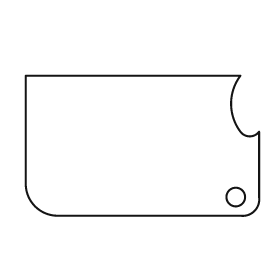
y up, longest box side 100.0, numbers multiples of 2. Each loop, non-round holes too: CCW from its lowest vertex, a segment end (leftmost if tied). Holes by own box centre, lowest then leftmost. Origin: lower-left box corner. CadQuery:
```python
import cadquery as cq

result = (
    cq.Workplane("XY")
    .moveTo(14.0, 0.0)
    .lineTo(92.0, 0.0)
    .threePointArc((98.0, 2.0), (100.0, 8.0))
    .lineTo(100.0, 36.0)
    .threePointArc((96.0, 34.0), (92.0, 36.0))
    .threePointArc((88.0, 48.0), (92.0, 60.0))
    .lineTo(0.0, 60.0)
    .lineTo(0.0, 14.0)
    .threePointArc((4.0, 4.0), (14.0, 0.0))
    .close()
    .moveTo(90.0, 8.0)
    .circle(4.0)
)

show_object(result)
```